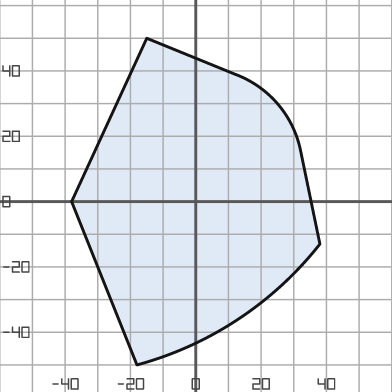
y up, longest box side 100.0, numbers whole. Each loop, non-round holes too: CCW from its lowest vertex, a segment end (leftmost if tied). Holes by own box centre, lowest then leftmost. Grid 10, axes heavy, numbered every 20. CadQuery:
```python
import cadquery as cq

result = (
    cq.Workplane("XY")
    .moveTo(-18.0, -50.0)
    .threePointArc((13.0, -36.0), (38.0, -13.0))
    .lineTo(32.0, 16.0)
    .threePointArc((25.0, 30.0), (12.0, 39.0))
    .lineTo(-15.0, 50.0)
    .lineTo(-38.0, 0.0)
    .close()
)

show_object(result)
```